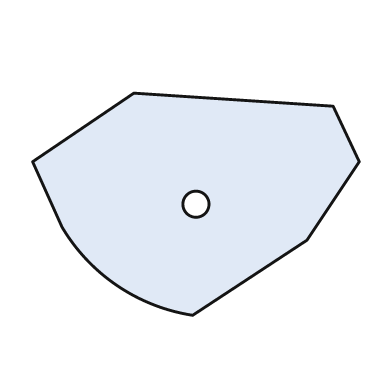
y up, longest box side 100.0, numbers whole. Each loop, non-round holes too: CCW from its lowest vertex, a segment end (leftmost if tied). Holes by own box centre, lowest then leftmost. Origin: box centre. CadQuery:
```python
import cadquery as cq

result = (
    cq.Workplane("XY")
    .moveTo(-1.0, -34.0)
    .lineTo(34.0, -11.0)
    .lineTo(50.0, 13.0)
    .lineTo(42.0, 30.0)
    .lineTo(-19.0, 34.0)
    .lineTo(-50.0, 13.0)
    .lineTo(-41.0, -7.0)
    .threePointArc((-24.0, -25.0), (-1.0, -34.0))
    .close()
    .moveTo(0.0, 0.0)
    .circle(4.0)
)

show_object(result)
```